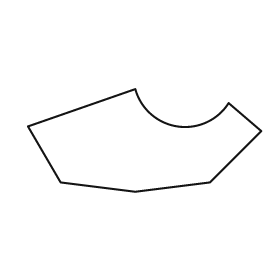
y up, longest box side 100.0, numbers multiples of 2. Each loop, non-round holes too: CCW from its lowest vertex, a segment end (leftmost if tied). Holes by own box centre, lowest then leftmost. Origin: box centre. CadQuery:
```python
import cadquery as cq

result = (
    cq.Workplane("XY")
    .moveTo(-4.0, -22.0)
    .lineTo(28.0, -18.0)
    .lineTo(50.0, 4.0)
    .lineTo(36.0, 16.0)
    .threePointArc((14.0, 6.0), (-4.0, 22.0))
    .lineTo(-50.0, 6.0)
    .lineTo(-36.0, -18.0)
    .close()
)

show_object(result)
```